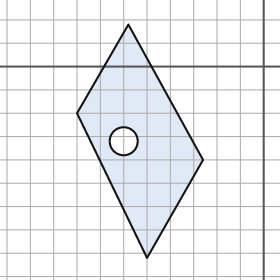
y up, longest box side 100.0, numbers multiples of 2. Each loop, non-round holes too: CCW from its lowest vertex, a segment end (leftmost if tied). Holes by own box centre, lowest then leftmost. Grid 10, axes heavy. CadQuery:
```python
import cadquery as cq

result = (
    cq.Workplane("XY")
    .moveTo(-50.0, -82.0)
    .lineTo(-26.0, -40.0)
    .lineTo(-58.0, 18.0)
    .lineTo(-80.0, -20.0)
    .close()
    .moveTo(-60.0, -32.0)
    .circle(6.0)
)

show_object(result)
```